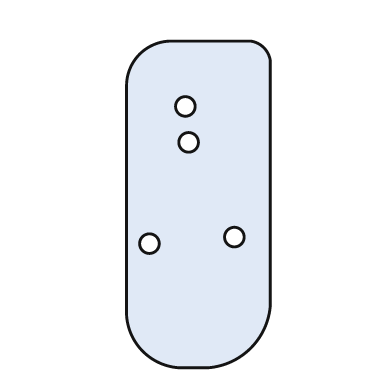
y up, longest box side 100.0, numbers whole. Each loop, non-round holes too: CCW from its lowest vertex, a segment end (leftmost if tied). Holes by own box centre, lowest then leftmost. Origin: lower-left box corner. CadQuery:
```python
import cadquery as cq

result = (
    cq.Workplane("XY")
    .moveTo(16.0, 0.0)
    .lineTo(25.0, 0.0)
    .threePointArc((38.0, 6.0), (44.0, 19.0))
    .lineTo(44.0, 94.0)
    .threePointArc((42.0, 98.0), (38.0, 100.0))
    .lineTo(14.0, 100.0)
    .threePointArc((4.0, 96.0), (0.0, 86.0))
    .lineTo(0.0, 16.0)
    .threePointArc((5.0, 5.0), (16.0, 0.0))
    .close()
    .moveTo(7.0, 38.0)
    .circle(3.0)
    .moveTo(33.0, 40.0)
    .circle(3.0)
    .moveTo(19.0, 69.0)
    .circle(3.0)
    .moveTo(18.0, 80.0)
    .circle(3.0)
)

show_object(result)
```